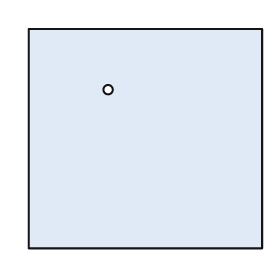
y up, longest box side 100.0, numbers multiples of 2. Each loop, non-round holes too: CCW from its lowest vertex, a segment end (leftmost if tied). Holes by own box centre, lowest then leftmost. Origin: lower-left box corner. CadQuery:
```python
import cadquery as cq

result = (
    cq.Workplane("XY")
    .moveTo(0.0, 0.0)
    .lineTo(100.0, 0.0)
    .lineTo(100.0, 94.0)
    .lineTo(0.0, 94.0)
    .close()
    .moveTo(34.0, 68.0)
    .circle(2.0)
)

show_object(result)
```